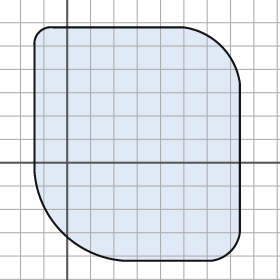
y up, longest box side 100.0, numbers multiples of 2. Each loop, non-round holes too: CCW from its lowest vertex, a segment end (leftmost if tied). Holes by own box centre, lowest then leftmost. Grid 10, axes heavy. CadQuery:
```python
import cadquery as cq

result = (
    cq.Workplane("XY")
    .moveTo(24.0, -42.0)
    .lineTo(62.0, -42.0)
    .threePointArc((70.0, -38.0), (74.0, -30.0))
    .lineTo(74.0, 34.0)
    .threePointArc((66.0, 50.0), (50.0, 58.0))
    .lineTo(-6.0, 58.0)
    .threePointArc((-12.0, 56.0), (-14.0, 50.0))
    .lineTo(-14.0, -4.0)
    .threePointArc((-2.0, -30.0), (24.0, -42.0))
    .close()
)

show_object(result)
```